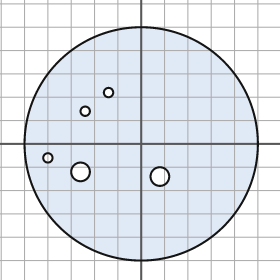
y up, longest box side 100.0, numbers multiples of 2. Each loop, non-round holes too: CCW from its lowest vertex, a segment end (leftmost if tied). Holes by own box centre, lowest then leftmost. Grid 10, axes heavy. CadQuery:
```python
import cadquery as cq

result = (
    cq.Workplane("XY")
    .moveTo(0.0, 0.0)
    .circle(50.0)
    .moveTo(8.0, -14.0)
    .circle(4.0)
    .moveTo(-26.0, -12.0)
    .circle(4.0)
    .moveTo(-40.0, -6.0)
    .circle(2.0)
    .moveTo(-24.0, 14.0)
    .circle(2.0)
    .moveTo(-14.0, 22.0)
    .circle(2.0)
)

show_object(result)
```